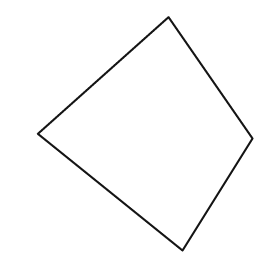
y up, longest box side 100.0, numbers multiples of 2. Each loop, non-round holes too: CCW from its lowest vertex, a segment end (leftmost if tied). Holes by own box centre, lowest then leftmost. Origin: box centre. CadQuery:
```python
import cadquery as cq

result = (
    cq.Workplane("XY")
    .moveTo(16.0, -50.0)
    .lineTo(46.0, -2.0)
    .lineTo(10.0, 50.0)
    .lineTo(-46.0, 0.0)
    .close()
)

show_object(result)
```